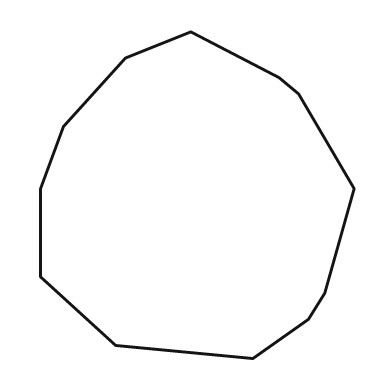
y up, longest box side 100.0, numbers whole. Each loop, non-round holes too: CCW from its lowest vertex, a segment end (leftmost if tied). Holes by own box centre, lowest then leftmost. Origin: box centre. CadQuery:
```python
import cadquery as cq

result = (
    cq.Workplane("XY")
    .moveTo(17.0, -50.0)
    .lineTo(34.0, -38.0)
    .lineTo(39.0, -30.0)
    .lineTo(48.0, 2.0)
    .lineTo(31.0, 31.0)
    .lineTo(25.0, 36.0)
    .lineTo(-2.0, 50.0)
    .lineTo(-22.0, 42.0)
    .lineTo(-41.0, 21.0)
    .lineTo(-48.0, 2.0)
    .lineTo(-48.0, -25.0)
    .lineTo(-25.0, -46.0)
    .close()
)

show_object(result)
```